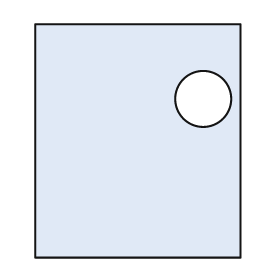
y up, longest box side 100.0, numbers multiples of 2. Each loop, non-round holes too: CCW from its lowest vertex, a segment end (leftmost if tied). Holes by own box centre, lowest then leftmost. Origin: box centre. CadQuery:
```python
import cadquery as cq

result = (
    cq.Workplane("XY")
    .moveTo(-44.0, -50.0)
    .lineTo(44.0, -50.0)
    .lineTo(44.0, 50.0)
    .lineTo(-44.0, 50.0)
    .close()
    .moveTo(28.0, 18.0)
    .circle(12.0)
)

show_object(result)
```